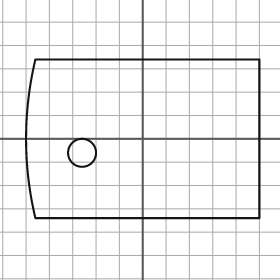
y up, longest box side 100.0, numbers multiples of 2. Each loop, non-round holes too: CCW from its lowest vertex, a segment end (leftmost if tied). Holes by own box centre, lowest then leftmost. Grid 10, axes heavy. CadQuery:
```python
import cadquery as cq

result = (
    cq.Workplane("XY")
    .moveTo(-46.0, -34.0)
    .lineTo(50.0, -34.0)
    .lineTo(50.0, 34.0)
    .lineTo(-46.0, 34.0)
    .threePointArc((-50.0, 0.0), (-46.0, -34.0))
    .close()
    .moveTo(-26.0, -6.0)
    .circle(6.0)
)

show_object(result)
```